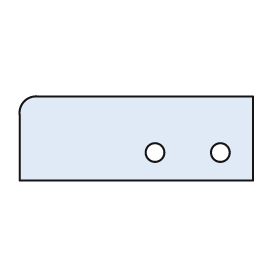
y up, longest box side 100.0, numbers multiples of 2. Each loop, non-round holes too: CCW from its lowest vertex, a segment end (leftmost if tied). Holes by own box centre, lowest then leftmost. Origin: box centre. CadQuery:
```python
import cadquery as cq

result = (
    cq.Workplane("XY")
    .moveTo(-50.0, -18.0)
    .lineTo(50.0, -18.0)
    .lineTo(50.0, 18.0)
    .lineTo(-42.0, 18.0)
    .threePointArc((-48.0, 16.0), (-50.0, 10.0))
    .close()
    .moveTo(8.0, -6.0)
    .circle(4.0)
    .moveTo(36.0, -6.0)
    .circle(4.0)
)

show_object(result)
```